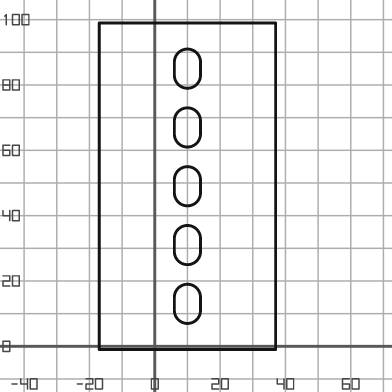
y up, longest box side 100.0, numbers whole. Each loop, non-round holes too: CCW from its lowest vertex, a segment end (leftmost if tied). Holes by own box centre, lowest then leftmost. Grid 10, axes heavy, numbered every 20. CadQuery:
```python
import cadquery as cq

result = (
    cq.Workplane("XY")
    .moveTo(-17.0, -1.0)
    .lineTo(37.0, -1.0)
    .lineTo(37.0, 99.0)
    .lineTo(-17.0, 99.0)
    .close()
    .moveTo(6.0, 11.0)
    .threePointArc((10.0, 7.0), (14.0, 11.0))
    .lineTo(14.0, 15.0)
    .threePointArc((10.0, 19.0), (6.0, 15.0))
    .close()
    .moveTo(6.0, 29.0)
    .threePointArc((10.0, 25.0), (14.0, 29.0))
    .lineTo(14.0, 33.0)
    .threePointArc((10.0, 37.0), (6.0, 33.0))
    .close()
    .moveTo(6.0, 47.0)
    .threePointArc((10.0, 43.0), (14.0, 47.0))
    .lineTo(14.0, 51.0)
    .threePointArc((10.0, 55.0), (6.0, 51.0))
    .close()
    .moveTo(6.0, 65.0)
    .threePointArc((10.0, 61.0), (14.0, 65.0))
    .lineTo(14.0, 69.0)
    .threePointArc((10.0, 73.0), (6.0, 69.0))
    .close()
    .moveTo(6.0, 83.0)
    .threePointArc((10.0, 79.0), (14.0, 83.0))
    .lineTo(14.0, 87.0)
    .threePointArc((10.0, 91.0), (6.0, 87.0))
    .close()
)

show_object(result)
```